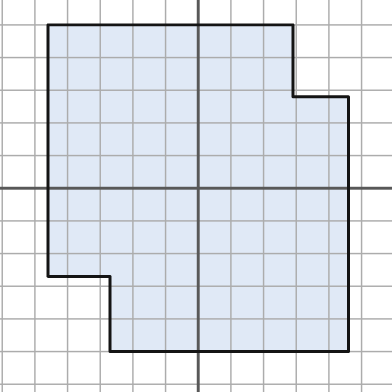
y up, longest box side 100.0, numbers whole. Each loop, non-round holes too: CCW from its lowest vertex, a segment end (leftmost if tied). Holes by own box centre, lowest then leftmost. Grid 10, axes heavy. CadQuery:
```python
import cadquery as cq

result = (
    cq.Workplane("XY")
    .moveTo(-27.0, -50.0)
    .lineTo(46.0, -50.0)
    .lineTo(46.0, 28.0)
    .lineTo(29.0, 28.0)
    .lineTo(29.0, 50.0)
    .lineTo(-46.0, 50.0)
    .lineTo(-46.0, -27.0)
    .lineTo(-27.0, -27.0)
    .close()
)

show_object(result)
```